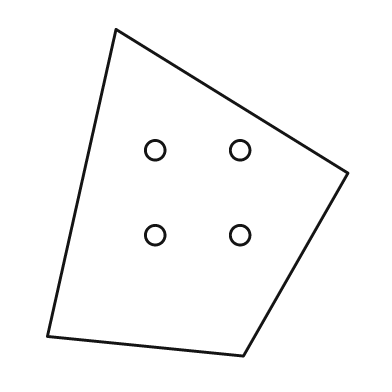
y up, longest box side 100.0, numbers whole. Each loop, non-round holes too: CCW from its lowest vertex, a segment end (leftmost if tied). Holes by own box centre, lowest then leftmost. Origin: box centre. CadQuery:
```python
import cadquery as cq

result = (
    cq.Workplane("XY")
    .moveTo(14.0, -50.0)
    .lineTo(46.0, 6.0)
    .lineTo(-25.0, 50.0)
    .lineTo(-46.0, -44.0)
    .close()
    .moveTo(-13.0, -13.0)
    .circle(3.0)
    .moveTo(13.0, -13.0)
    .circle(3.0)
    .moveTo(-13.0, 13.0)
    .circle(3.0)
    .moveTo(13.0, 13.0)
    .circle(3.0)
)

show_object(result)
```